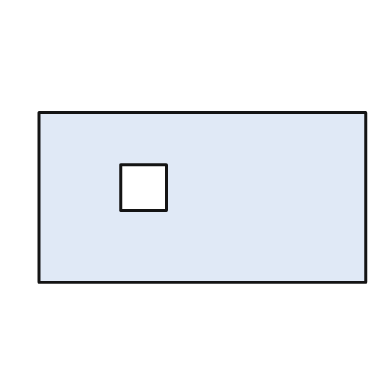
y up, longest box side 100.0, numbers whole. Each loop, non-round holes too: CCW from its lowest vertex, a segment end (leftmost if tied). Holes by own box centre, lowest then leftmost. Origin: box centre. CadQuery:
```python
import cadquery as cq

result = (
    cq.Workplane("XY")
    .moveTo(-50.0, -26.0)
    .lineTo(50.0, -26.0)
    .lineTo(50.0, 26.0)
    .lineTo(-50.0, 26.0)
    .close()
    .moveTo(-25.0, -4.0)
    .lineTo(-11.0, -4.0)
    .lineTo(-11.0, 10.0)
    .lineTo(-25.0, 10.0)
    .close()
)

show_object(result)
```